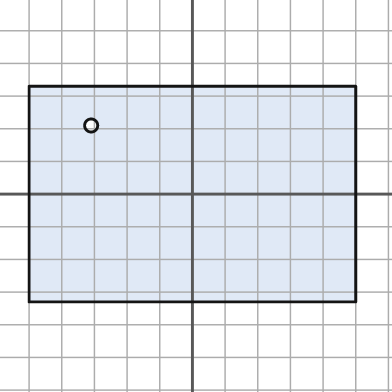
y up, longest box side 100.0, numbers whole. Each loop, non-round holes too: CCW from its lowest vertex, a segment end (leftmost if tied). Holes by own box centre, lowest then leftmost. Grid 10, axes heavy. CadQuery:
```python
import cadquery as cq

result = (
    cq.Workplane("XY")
    .moveTo(-50.0, -33.0)
    .lineTo(50.0, -33.0)
    .lineTo(50.0, 33.0)
    .lineTo(-50.0, 33.0)
    .close()
    .moveTo(-31.0, 21.0)
    .circle(2.0)
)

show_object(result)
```